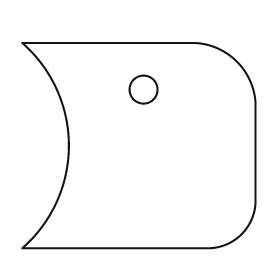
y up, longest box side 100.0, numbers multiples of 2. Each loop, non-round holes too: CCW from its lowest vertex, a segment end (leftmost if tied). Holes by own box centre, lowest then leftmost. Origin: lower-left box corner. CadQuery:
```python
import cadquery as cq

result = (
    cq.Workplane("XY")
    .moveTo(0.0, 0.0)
    .lineTo(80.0, 0.0)
    .threePointArc((94.0, 6.0), (100.0, 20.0))
    .lineTo(100.0, 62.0)
    .threePointArc((92.0, 80.0), (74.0, 88.0))
    .lineTo(0.0, 88.0)
    .threePointArc((20.0, 44.0), (0.0, 0.0))
    .close()
    .moveTo(52.0, 68.0)
    .circle(6.0)
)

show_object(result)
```